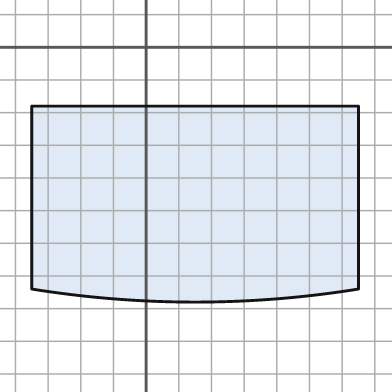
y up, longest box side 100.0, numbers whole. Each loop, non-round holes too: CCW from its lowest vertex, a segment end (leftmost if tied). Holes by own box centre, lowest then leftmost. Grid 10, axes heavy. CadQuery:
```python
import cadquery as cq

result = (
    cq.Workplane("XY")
    .moveTo(-35.0, -74.0)
    .threePointArc((15.0, -78.0), (65.0, -74.0))
    .lineTo(65.0, -18.0)
    .lineTo(-35.0, -18.0)
    .close()
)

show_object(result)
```